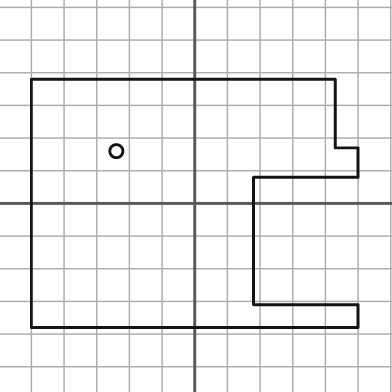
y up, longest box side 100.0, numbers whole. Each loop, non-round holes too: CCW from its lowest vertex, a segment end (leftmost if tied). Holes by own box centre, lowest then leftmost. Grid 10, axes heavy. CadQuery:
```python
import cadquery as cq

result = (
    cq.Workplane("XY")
    .moveTo(-50.0, -38.0)
    .lineTo(50.0, -38.0)
    .lineTo(50.0, -31.0)
    .lineTo(18.0, -31.0)
    .lineTo(18.0, 8.0)
    .lineTo(50.0, 8.0)
    .lineTo(50.0, 17.0)
    .lineTo(43.0, 17.0)
    .lineTo(43.0, 38.0)
    .lineTo(-50.0, 38.0)
    .close()
    .moveTo(-24.0, 16.0)
    .circle(2.0)
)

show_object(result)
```